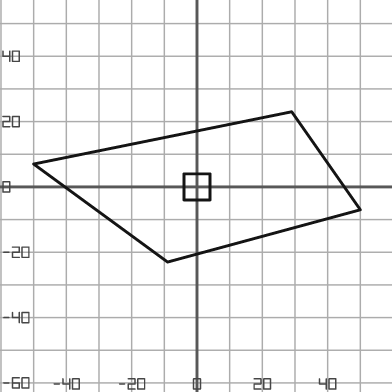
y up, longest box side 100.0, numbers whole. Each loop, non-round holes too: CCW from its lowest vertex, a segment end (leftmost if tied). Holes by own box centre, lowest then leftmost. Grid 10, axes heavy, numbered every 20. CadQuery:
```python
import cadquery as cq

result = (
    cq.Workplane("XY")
    .moveTo(-9.0, -23.0)
    .lineTo(50.0, -7.0)
    .lineTo(29.0, 23.0)
    .lineTo(-50.0, 7.0)
    .close()
    .moveTo(-4.0, -4.0)
    .lineTo(4.0, -4.0)
    .lineTo(4.0, 4.0)
    .lineTo(-4.0, 4.0)
    .close()
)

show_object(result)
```